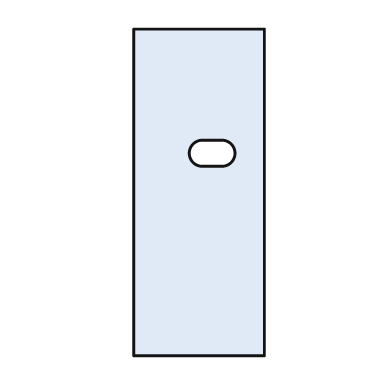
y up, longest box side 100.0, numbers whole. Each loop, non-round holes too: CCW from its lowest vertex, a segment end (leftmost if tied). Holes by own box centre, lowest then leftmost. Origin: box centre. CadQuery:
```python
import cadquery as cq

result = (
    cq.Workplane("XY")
    .moveTo(-20.0, -50.0)
    .lineTo(20.0, -50.0)
    .lineTo(20.0, 50.0)
    .lineTo(-20.0, 50.0)
    .close()
    .moveTo(1.0, 8.0)
    .lineTo(7.0, 8.0)
    .threePointArc((11.0, 12.0), (7.0, 16.0))
    .lineTo(1.0, 16.0)
    .threePointArc((-3.0, 12.0), (1.0, 8.0))
    .close()
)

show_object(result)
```